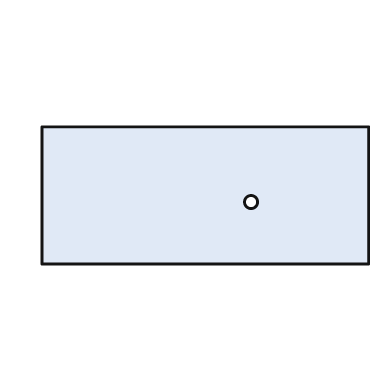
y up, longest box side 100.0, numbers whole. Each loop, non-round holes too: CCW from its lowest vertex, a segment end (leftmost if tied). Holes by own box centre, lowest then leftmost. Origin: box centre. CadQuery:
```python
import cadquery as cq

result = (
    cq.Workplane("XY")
    .moveTo(-50.0, -21.0)
    .lineTo(50.0, -21.0)
    .lineTo(50.0, 21.0)
    .lineTo(-50.0, 21.0)
    .close()
    .moveTo(14.0, -2.0)
    .circle(2.0)
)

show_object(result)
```